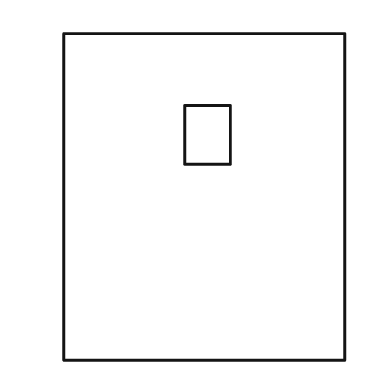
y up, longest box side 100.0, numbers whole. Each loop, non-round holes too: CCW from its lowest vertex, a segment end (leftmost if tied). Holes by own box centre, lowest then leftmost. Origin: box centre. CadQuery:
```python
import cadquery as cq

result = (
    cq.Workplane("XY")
    .moveTo(-43.0, -50.0)
    .lineTo(43.0, -50.0)
    .lineTo(43.0, 50.0)
    .lineTo(-43.0, 50.0)
    .close()
    .moveTo(-6.0, 10.0)
    .lineTo(8.0, 10.0)
    .lineTo(8.0, 28.0)
    .lineTo(-6.0, 28.0)
    .close()
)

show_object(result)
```